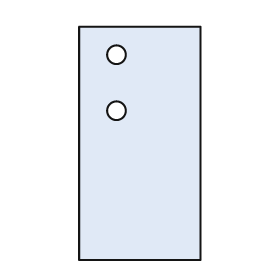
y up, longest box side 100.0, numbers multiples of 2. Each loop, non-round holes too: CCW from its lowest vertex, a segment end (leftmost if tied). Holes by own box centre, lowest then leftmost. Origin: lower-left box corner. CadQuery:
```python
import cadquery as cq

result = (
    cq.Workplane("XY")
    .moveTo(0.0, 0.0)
    .lineTo(52.0, 0.0)
    .lineTo(52.0, 100.0)
    .lineTo(0.0, 100.0)
    .close()
    .moveTo(16.0, 64.0)
    .circle(4.0)
    .moveTo(16.0, 88.0)
    .circle(4.0)
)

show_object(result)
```